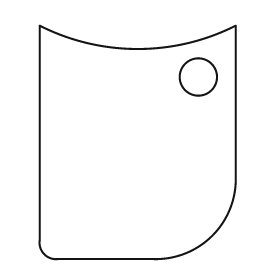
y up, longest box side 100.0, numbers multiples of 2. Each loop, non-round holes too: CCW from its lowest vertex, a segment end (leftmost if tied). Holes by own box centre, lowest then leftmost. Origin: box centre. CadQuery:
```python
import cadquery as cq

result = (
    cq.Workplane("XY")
    .moveTo(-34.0, -50.0)
    .lineTo(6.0, -50.0)
    .threePointArc((32.0, -40.0), (42.0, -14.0))
    .lineTo(42.0, 50.0)
    .threePointArc((0.0, 40.0), (-42.0, 50.0))
    .lineTo(-42.0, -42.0)
    .threePointArc((-40.0, -48.0), (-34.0, -50.0))
    .close()
    .moveTo(26.0, 28.0)
    .circle(8.0)
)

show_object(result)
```